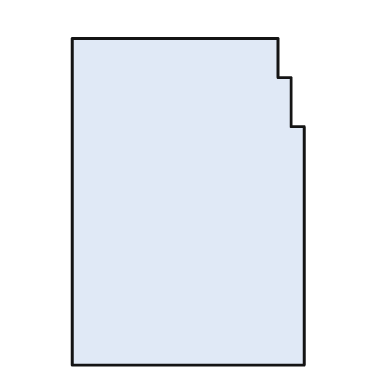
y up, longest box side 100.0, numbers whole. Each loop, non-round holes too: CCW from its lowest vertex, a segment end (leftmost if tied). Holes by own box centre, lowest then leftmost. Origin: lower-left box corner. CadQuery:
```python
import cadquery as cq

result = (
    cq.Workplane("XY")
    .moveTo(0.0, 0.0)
    .lineTo(71.0, 0.0)
    .lineTo(71.0, 73.0)
    .lineTo(67.0, 73.0)
    .lineTo(67.0, 88.0)
    .lineTo(63.0, 88.0)
    .lineTo(63.0, 100.0)
    .lineTo(0.0, 100.0)
    .close()
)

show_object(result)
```